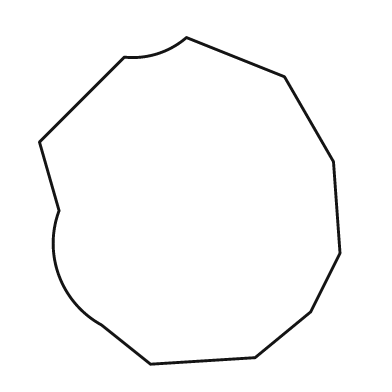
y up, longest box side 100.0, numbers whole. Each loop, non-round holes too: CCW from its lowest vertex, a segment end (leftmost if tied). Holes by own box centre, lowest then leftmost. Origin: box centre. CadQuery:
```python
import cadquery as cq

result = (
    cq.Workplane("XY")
    .moveTo(-12.0, -50.0)
    .lineTo(20.0, -48.0)
    .lineTo(37.0, -34.0)
    .lineTo(46.0, -16.0)
    .lineTo(44.0, 12.0)
    .lineTo(29.0, 38.0)
    .lineTo(-1.0, 50.0)
    .threePointArc((-10.0, 45.0), (-20.0, 44.0))
    .lineTo(-46.0, 18.0)
    .lineTo(-40.0, -3.0)
    .threePointArc((-40.0, -23.0), (-27.0, -38.0))
    .close()
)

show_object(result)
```